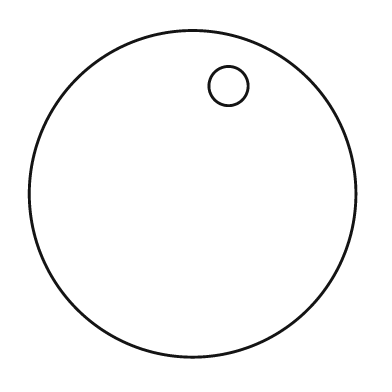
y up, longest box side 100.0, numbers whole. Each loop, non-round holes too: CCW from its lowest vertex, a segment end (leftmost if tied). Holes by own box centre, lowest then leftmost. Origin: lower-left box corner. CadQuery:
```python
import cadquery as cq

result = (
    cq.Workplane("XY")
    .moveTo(50.0, 50.0)
    .circle(50.0)
    .moveTo(61.0, 83.0)
    .circle(6.0)
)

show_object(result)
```